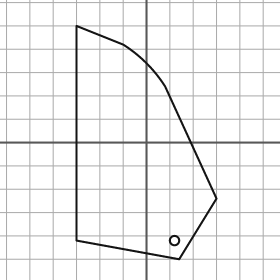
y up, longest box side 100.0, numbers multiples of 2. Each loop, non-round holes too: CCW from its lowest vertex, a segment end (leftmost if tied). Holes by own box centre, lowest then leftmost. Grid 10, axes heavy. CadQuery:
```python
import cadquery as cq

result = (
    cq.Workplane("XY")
    .moveTo(14.0, -50.0)
    .lineTo(30.0, -24.0)
    .lineTo(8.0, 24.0)
    .threePointArc((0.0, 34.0), (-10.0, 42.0))
    .lineTo(-30.0, 50.0)
    .lineTo(-30.0, -42.0)
    .close()
    .moveTo(12.0, -42.0)
    .circle(2.0)
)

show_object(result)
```